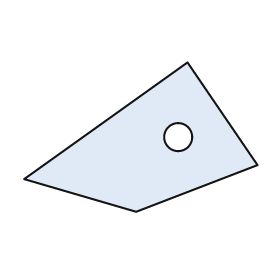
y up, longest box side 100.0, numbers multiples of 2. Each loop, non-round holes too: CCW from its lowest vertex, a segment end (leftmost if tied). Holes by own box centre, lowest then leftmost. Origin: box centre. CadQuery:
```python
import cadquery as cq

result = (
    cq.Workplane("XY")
    .moveTo(-2.0, -32.0)
    .lineTo(50.0, -12.0)
    .lineTo(20.0, 32.0)
    .lineTo(-50.0, -18.0)
    .close()
    .moveTo(16.0, 0.0)
    .circle(6.0)
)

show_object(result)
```